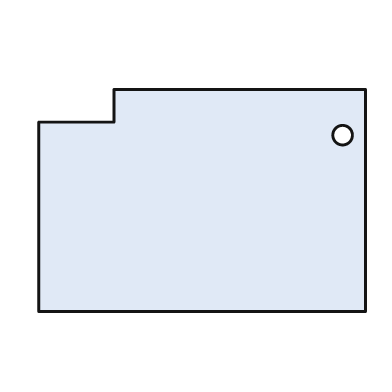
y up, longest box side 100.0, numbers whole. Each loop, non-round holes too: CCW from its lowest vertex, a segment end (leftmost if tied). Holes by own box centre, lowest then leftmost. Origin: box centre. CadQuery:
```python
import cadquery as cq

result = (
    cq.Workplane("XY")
    .moveTo(-50.0, -34.0)
    .lineTo(50.0, -34.0)
    .lineTo(50.0, 34.0)
    .lineTo(-27.0, 34.0)
    .lineTo(-27.0, 24.0)
    .lineTo(-50.0, 24.0)
    .close()
    .moveTo(43.0, 20.0)
    .circle(3.0)
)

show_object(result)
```